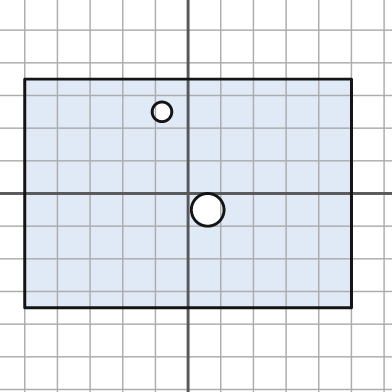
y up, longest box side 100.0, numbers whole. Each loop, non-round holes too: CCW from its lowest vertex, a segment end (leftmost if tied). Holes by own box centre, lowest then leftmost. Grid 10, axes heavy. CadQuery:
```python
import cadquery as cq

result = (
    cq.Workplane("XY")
    .moveTo(-50.0, -35.0)
    .lineTo(50.0, -35.0)
    .lineTo(50.0, 35.0)
    .lineTo(-50.0, 35.0)
    .close()
    .moveTo(6.0, -5.0)
    .circle(5.0)
    .moveTo(-8.0, 25.0)
    .circle(3.0)
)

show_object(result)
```